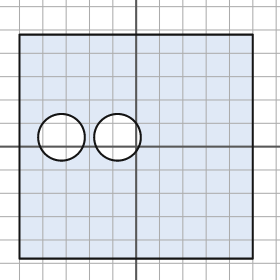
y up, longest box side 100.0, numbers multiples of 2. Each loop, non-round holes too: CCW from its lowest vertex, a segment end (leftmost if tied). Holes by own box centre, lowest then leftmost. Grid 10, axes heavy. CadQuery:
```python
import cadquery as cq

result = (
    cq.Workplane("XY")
    .moveTo(-50.0, -48.0)
    .lineTo(50.0, -48.0)
    .lineTo(50.0, 48.0)
    .lineTo(-50.0, 48.0)
    .close()
    .moveTo(-32.0, 4.0)
    .circle(10.0)
    .moveTo(-8.0, 4.0)
    .circle(10.0)
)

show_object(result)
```